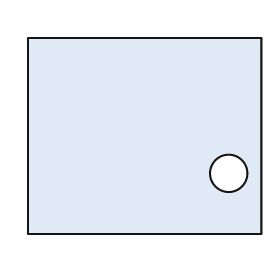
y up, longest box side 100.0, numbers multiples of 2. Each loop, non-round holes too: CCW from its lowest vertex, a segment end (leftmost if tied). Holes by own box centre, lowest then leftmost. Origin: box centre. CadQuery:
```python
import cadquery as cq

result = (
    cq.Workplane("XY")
    .moveTo(-50.0, -42.0)
    .lineTo(50.0, -42.0)
    .lineTo(50.0, 42.0)
    .lineTo(-50.0, 42.0)
    .close()
    .moveTo(36.0, -16.0)
    .circle(8.0)
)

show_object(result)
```